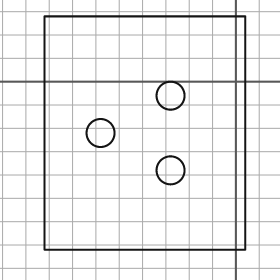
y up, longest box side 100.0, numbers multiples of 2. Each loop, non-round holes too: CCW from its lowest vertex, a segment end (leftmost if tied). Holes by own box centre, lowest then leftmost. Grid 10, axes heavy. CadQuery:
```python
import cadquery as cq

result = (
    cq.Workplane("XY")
    .moveTo(-82.0, -72.0)
    .lineTo(4.0, -72.0)
    .lineTo(4.0, 28.0)
    .lineTo(-82.0, 28.0)
    .close()
    .moveTo(-28.0, -38.0)
    .circle(6.0)
    .moveTo(-58.0, -22.0)
    .circle(6.0)
    .moveTo(-28.0, -6.0)
    .circle(6.0)
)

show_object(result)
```